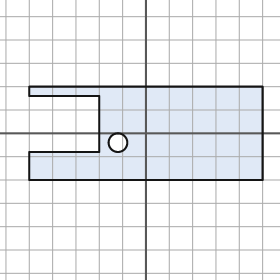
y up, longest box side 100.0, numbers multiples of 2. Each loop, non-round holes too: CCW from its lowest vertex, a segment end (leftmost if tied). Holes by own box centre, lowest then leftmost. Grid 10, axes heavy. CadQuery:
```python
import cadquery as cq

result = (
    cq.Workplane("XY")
    .moveTo(-50.0, -20.0)
    .lineTo(50.0, -20.0)
    .lineTo(50.0, 20.0)
    .lineTo(-50.0, 20.0)
    .lineTo(-50.0, 16.0)
    .lineTo(-20.0, 16.0)
    .lineTo(-20.0, -8.0)
    .lineTo(-50.0, -8.0)
    .close()
    .moveTo(-12.0, -4.0)
    .circle(4.0)
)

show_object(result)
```